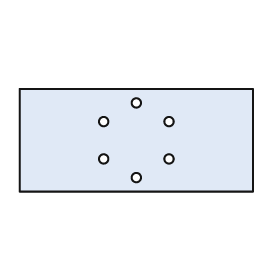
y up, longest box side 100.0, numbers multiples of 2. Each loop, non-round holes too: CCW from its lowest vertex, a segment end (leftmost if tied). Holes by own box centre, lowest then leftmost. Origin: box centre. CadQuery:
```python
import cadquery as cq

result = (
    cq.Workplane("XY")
    .moveTo(-50.0, -22.0)
    .lineTo(50.0, -22.0)
    .lineTo(50.0, 22.0)
    .lineTo(-50.0, 22.0)
    .close()
    .moveTo(0.0, -16.0)
    .circle(2.0)
    .moveTo(-14.0, -8.0)
    .circle(2.0)
    .moveTo(14.0, -8.0)
    .circle(2.0)
    .moveTo(-14.0, 8.0)
    .circle(2.0)
    .moveTo(14.0, 8.0)
    .circle(2.0)
    .moveTo(0.0, 16.0)
    .circle(2.0)
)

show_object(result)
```